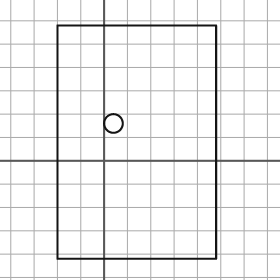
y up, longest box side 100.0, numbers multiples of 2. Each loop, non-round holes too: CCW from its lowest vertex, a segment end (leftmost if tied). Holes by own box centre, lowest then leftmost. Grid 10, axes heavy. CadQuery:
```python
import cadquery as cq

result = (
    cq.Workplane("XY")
    .moveTo(-20.0, -42.0)
    .lineTo(48.0, -42.0)
    .lineTo(48.0, 58.0)
    .lineTo(-20.0, 58.0)
    .close()
    .moveTo(4.0, 16.0)
    .circle(4.0)
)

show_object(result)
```